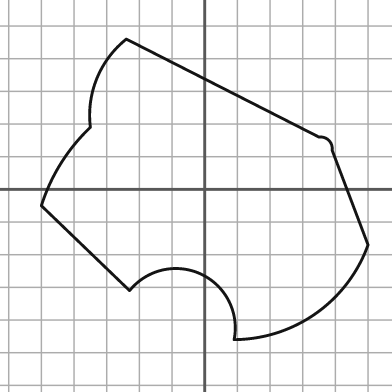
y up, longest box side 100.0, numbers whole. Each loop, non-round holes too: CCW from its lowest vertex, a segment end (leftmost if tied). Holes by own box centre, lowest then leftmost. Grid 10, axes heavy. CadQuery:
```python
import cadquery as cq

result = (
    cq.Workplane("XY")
    .moveTo(9.0, -46.0)
    .threePointArc((34.0, -38.0), (50.0, -17.0))
    .lineTo(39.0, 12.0)
    .threePointArc((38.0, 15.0), (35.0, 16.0))
    .lineTo(-24.0, 46.0)
    .threePointArc((-33.0, 34.0), (-35.0, 19.0))
    .threePointArc((-44.0, 8.0), (-50.0, -5.0))
    .lineTo(-23.0, -31.0)
    .threePointArc((-1.0, -26.0), (9.0, -46.0))
    .close()
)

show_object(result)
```